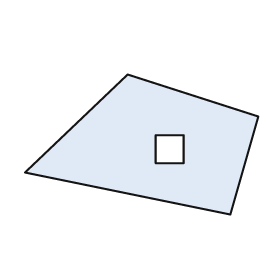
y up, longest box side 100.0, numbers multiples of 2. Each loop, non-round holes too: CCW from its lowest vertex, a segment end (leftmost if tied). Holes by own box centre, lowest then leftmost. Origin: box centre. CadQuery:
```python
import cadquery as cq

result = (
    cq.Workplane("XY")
    .moveTo(38.0, -30.0)
    .lineTo(50.0, 12.0)
    .lineTo(-6.0, 30.0)
    .lineTo(-50.0, -12.0)
    .close()
    .moveTo(6.0, -8.0)
    .lineTo(18.0, -8.0)
    .lineTo(18.0, 4.0)
    .lineTo(6.0, 4.0)
    .close()
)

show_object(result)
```